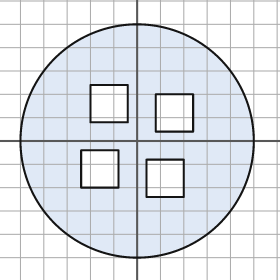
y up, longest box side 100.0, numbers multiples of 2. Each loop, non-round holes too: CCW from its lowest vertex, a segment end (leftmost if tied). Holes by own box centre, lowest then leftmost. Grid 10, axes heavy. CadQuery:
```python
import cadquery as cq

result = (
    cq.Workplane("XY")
    .moveTo(0.0, 0.0)
    .circle(50.0)
    .moveTo(4.0, -24.0)
    .lineTo(20.0, -24.0)
    .lineTo(20.0, -8.0)
    .lineTo(4.0, -8.0)
    .close()
    .moveTo(-24.0, -20.0)
    .lineTo(-8.0, -20.0)
    .lineTo(-8.0, -4.0)
    .lineTo(-24.0, -4.0)
    .close()
    .moveTo(8.0, 4.0)
    .lineTo(24.0, 4.0)
    .lineTo(24.0, 20.0)
    .lineTo(8.0, 20.0)
    .close()
    .moveTo(-20.0, 8.0)
    .lineTo(-4.0, 8.0)
    .lineTo(-4.0, 24.0)
    .lineTo(-20.0, 24.0)
    .close()
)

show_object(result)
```